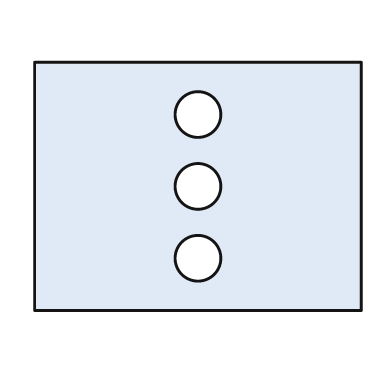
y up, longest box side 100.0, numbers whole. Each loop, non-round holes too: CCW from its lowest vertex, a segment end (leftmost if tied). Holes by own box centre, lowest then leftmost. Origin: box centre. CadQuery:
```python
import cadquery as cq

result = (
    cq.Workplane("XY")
    .moveTo(-50.0, -38.0)
    .lineTo(50.0, -38.0)
    .lineTo(50.0, 38.0)
    .lineTo(-50.0, 38.0)
    .close()
    .moveTo(0.0, -22.0)
    .circle(7.0)
    .moveTo(0.0, 0.0)
    .circle(7.0)
    .moveTo(0.0, 22.0)
    .circle(7.0)
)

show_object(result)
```